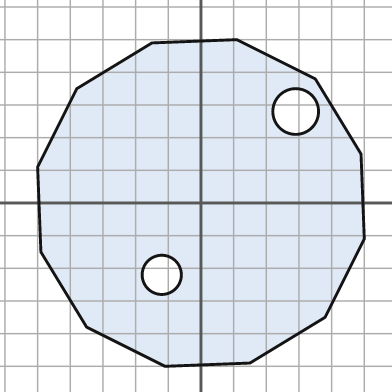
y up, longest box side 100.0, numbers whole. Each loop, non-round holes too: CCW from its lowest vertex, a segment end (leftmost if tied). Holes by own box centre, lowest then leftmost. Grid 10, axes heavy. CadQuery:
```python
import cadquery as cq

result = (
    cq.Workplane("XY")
    .moveTo(-11.0, -50.0)
    .lineTo(15.0, -49.0)
    .lineTo(38.0, -35.0)
    .lineTo(50.0, -11.0)
    .lineTo(49.0, 15.0)
    .lineTo(35.0, 38.0)
    .lineTo(11.0, 50.0)
    .lineTo(-15.0, 49.0)
    .lineTo(-38.0, 35.0)
    .lineTo(-50.0, 11.0)
    .lineTo(-49.0, -15.0)
    .lineTo(-35.0, -38.0)
    .close()
    .moveTo(-12.0, -22.0)
    .circle(6.0)
    .moveTo(29.0, 28.0)
    .circle(7.0)
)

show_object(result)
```